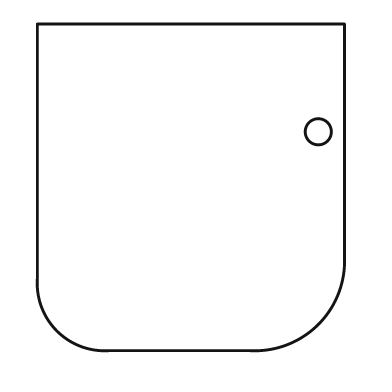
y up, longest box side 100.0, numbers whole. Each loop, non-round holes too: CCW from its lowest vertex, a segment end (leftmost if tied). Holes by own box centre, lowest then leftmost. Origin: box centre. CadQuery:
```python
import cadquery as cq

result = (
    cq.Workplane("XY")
    .moveTo(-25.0, -50.0)
    .lineTo(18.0, -50.0)
    .threePointArc((39.0, -42.0), (47.0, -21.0))
    .lineTo(47.0, 50.0)
    .lineTo(-47.0, 50.0)
    .lineTo(-47.0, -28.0)
    .threePointArc((-41.0, -44.0), (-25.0, -50.0))
    .close()
    .moveTo(39.0, 17.0)
    .circle(4.0)
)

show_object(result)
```